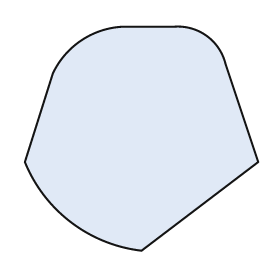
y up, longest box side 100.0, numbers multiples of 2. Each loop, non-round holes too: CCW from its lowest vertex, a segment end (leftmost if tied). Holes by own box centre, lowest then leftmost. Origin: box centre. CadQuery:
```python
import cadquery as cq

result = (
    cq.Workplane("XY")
    .moveTo(0.0, -48.0)
    .lineTo(50.0, -10.0)
    .lineTo(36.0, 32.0)
    .threePointArc((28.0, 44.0), (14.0, 48.0))
    .lineTo(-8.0, 48.0)
    .threePointArc((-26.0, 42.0), (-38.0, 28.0))
    .lineTo(-50.0, -10.0)
    .threePointArc((-30.0, -36.0), (0.0, -48.0))
    .close()
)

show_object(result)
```